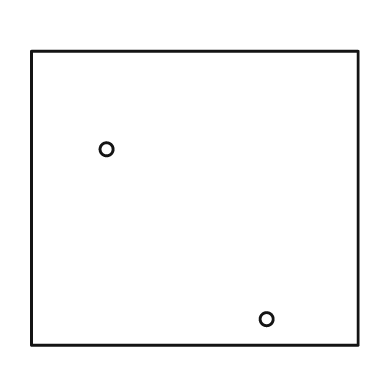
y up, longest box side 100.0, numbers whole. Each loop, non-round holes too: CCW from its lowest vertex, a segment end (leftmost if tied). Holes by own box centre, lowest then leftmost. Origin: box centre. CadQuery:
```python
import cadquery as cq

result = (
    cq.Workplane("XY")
    .moveTo(-50.0, -45.0)
    .lineTo(50.0, -45.0)
    .lineTo(50.0, 45.0)
    .lineTo(-50.0, 45.0)
    .close()
    .moveTo(22.0, -37.0)
    .circle(2.0)
    .moveTo(-27.0, 15.0)
    .circle(2.0)
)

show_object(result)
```